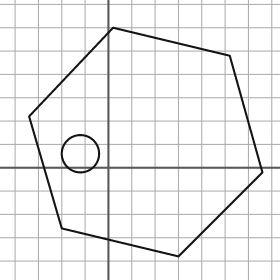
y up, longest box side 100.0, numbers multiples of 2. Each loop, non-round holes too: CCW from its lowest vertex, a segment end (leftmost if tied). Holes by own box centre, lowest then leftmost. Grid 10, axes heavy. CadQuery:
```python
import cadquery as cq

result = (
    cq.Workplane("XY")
    .moveTo(30.0, -38.0)
    .lineTo(66.0, -2.0)
    .lineTo(52.0, 48.0)
    .lineTo(2.0, 60.0)
    .lineTo(-34.0, 22.0)
    .lineTo(-20.0, -26.0)
    .close()
    .moveTo(-12.0, 6.0)
    .circle(8.0)
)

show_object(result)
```